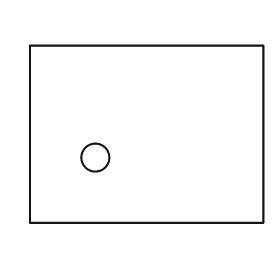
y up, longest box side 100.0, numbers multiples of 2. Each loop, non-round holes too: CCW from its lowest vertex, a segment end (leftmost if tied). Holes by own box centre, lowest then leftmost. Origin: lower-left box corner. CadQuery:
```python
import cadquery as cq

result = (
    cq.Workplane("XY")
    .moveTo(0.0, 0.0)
    .lineTo(100.0, 0.0)
    .lineTo(100.0, 76.0)
    .lineTo(0.0, 76.0)
    .close()
    .moveTo(28.0, 28.0)
    .circle(6.0)
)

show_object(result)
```